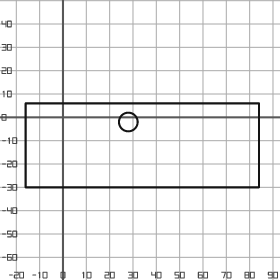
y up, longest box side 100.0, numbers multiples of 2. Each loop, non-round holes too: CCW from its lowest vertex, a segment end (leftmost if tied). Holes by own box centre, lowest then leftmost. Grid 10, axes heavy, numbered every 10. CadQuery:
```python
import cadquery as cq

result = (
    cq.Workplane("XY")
    .moveTo(-16.0, -30.0)
    .lineTo(84.0, -30.0)
    .lineTo(84.0, 6.0)
    .lineTo(-16.0, 6.0)
    .close()
    .moveTo(28.0, -2.0)
    .circle(4.0)
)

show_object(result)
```